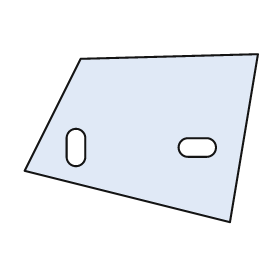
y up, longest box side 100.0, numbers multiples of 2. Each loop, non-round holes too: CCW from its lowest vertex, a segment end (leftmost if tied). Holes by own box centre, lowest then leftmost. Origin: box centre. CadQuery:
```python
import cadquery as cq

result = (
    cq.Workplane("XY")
    .moveTo(38.0, -36.0)
    .lineTo(50.0, 36.0)
    .lineTo(-26.0, 34.0)
    .lineTo(-50.0, -14.0)
    .close()
    .moveTo(-32.0, -8.0)
    .threePointArc((-28.0, -12.0), (-24.0, -8.0))
    .lineTo(-24.0, 0.0)
    .threePointArc((-28.0, 4.0), (-32.0, 0.0))
    .close()
    .moveTo(20.0, -8.0)
    .lineTo(28.0, -8.0)
    .threePointArc((32.0, -4.0), (28.0, 0.0))
    .lineTo(20.0, 0.0)
    .threePointArc((16.0, -4.0), (20.0, -8.0))
    .close()
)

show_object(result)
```